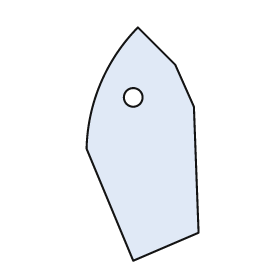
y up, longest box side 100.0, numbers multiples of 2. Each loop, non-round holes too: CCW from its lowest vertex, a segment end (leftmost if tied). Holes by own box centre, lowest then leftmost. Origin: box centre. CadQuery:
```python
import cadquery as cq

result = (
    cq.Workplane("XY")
    .moveTo(-4.0, -50.0)
    .lineTo(24.0, -38.0)
    .lineTo(22.0, 16.0)
    .lineTo(14.0, 34.0)
    .lineTo(-2.0, 50.0)
    .threePointArc((-18.0, 26.0), (-24.0, -2.0))
    .close()
    .moveTo(-4.0, 20.0)
    .circle(4.0)
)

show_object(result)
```